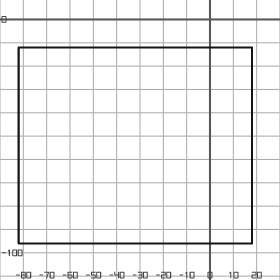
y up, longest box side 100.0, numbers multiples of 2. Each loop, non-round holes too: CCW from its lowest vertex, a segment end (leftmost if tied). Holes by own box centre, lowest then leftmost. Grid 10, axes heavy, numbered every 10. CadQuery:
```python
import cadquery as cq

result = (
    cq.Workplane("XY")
    .moveTo(-82.0, -96.0)
    .lineTo(18.0, -96.0)
    .lineTo(18.0, -12.0)
    .lineTo(-82.0, -12.0)
    .close()
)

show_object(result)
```